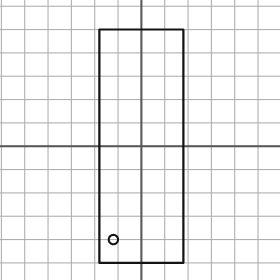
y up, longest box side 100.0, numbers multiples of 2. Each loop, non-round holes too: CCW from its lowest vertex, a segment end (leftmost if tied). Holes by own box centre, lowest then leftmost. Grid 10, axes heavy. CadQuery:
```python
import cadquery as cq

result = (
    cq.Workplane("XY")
    .moveTo(-18.0, -50.0)
    .lineTo(18.0, -50.0)
    .lineTo(18.0, 50.0)
    .lineTo(-18.0, 50.0)
    .close()
    .moveTo(-12.0, -40.0)
    .circle(2.0)
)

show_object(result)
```